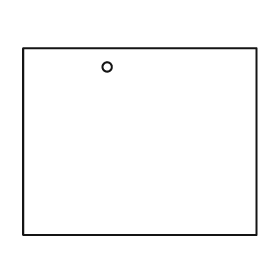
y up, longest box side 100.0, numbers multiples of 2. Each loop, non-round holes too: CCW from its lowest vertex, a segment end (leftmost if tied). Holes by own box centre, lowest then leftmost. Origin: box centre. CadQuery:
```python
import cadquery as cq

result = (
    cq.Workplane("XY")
    .moveTo(-50.0, -40.0)
    .lineTo(50.0, -40.0)
    .lineTo(50.0, 40.0)
    .lineTo(-50.0, 40.0)
    .close()
    .moveTo(-14.0, 32.0)
    .circle(2.0)
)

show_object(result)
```